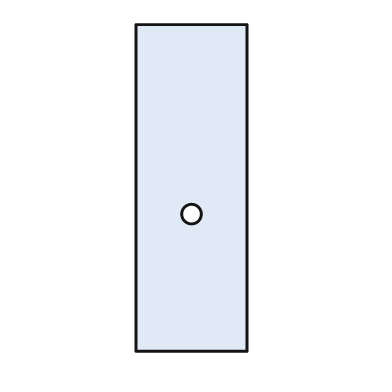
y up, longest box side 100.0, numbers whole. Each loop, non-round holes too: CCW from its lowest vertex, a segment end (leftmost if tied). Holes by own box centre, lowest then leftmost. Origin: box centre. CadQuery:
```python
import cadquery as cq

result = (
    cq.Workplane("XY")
    .moveTo(-17.0, -50.0)
    .lineTo(17.0, -50.0)
    .lineTo(17.0, 50.0)
    .lineTo(-17.0, 50.0)
    .close()
    .moveTo(0.0, -8.0)
    .circle(3.0)
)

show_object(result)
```